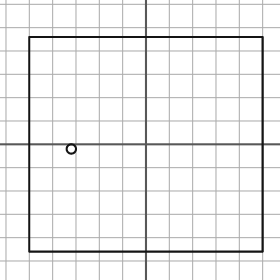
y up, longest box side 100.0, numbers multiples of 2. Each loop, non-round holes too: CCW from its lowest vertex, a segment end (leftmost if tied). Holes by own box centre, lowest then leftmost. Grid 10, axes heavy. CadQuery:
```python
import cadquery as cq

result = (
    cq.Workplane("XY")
    .moveTo(-50.0, -46.0)
    .lineTo(50.0, -46.0)
    .lineTo(50.0, 46.0)
    .lineTo(-50.0, 46.0)
    .close()
    .moveTo(-32.0, -2.0)
    .circle(2.0)
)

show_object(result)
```